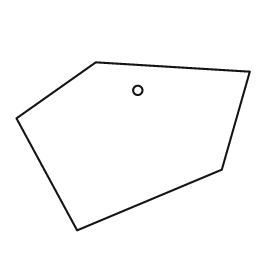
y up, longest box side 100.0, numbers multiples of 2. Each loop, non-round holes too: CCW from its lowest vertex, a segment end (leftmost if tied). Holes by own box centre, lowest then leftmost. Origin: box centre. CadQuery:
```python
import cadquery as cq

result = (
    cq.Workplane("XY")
    .moveTo(-24.0, -36.0)
    .lineTo(38.0, -10.0)
    .lineTo(50.0, 32.0)
    .lineTo(-16.0, 36.0)
    .lineTo(-50.0, 12.0)
    .close()
    .moveTo(2.0, 24.0)
    .circle(2.0)
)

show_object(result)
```